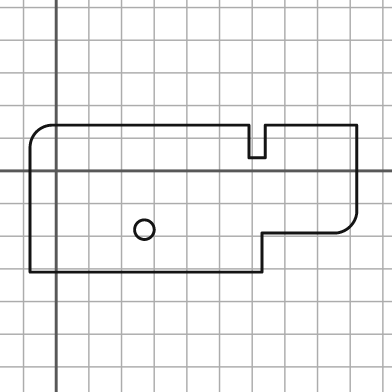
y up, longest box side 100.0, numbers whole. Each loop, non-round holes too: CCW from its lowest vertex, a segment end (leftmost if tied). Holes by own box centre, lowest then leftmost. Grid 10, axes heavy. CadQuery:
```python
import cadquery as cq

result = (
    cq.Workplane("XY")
    .moveTo(-8.0, -31.0)
    .lineTo(63.0, -31.0)
    .lineTo(63.0, -19.0)
    .lineTo(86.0, -19.0)
    .threePointArc((90.0, -17.0), (92.0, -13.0))
    .lineTo(92.0, 14.0)
    .lineTo(64.0, 14.0)
    .lineTo(64.0, 4.0)
    .lineTo(59.0, 4.0)
    .lineTo(59.0, 14.0)
    .lineTo(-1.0, 14.0)
    .threePointArc((-6.0, 12.0), (-8.0, 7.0))
    .close()
    .moveTo(27.0, -18.0)
    .circle(3.0)
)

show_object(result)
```